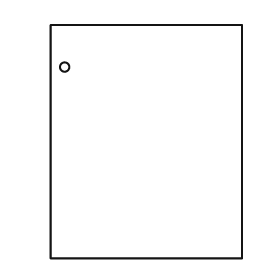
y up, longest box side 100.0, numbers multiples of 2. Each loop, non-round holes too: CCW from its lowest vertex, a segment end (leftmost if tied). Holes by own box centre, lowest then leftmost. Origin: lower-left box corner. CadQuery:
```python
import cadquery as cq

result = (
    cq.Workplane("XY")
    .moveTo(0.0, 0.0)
    .lineTo(82.0, 0.0)
    .lineTo(82.0, 100.0)
    .lineTo(0.0, 100.0)
    .close()
    .moveTo(6.0, 82.0)
    .circle(2.0)
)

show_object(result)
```